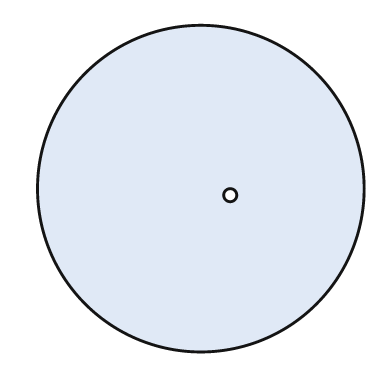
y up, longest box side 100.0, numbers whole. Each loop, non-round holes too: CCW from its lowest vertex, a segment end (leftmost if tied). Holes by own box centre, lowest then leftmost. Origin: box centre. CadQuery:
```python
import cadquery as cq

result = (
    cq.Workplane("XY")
    .moveTo(0.0, 0.0)
    .circle(50.0)
    .moveTo(9.0, -2.0)
    .circle(2.0)
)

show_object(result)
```